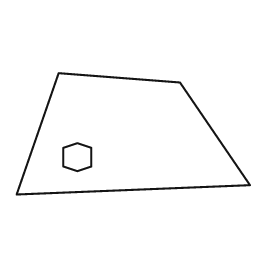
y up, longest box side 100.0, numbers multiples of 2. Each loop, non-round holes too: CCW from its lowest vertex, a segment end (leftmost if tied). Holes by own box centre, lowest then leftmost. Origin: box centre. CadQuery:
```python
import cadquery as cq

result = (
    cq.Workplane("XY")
    .moveTo(-50.0, -26.0)
    .lineTo(50.0, -22.0)
    .lineTo(20.0, 22.0)
    .lineTo(-32.0, 26.0)
    .close()
    .moveTo(-24.0, -16.0)
    .lineTo(-18.0, -14.0)
    .lineTo(-18.0, -6.0)
    .lineTo(-24.0, -4.0)
    .lineTo(-30.0, -6.0)
    .lineTo(-30.0, -14.0)
    .close()
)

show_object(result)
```